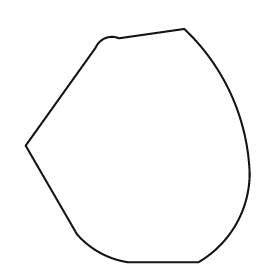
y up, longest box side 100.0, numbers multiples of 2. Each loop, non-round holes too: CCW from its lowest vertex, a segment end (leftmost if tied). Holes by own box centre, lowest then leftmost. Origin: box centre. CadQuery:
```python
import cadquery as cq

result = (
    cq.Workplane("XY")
    .moveTo(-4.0, -50.0)
    .lineTo(26.0, -50.0)
    .threePointArc((42.0, -34.0), (48.0, -12.0))
    .threePointArc((40.0, 22.0), (20.0, 50.0))
    .lineTo(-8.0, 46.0)
    .threePointArc((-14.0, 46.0), (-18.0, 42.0))
    .lineTo(-48.0, 0.0)
    .lineTo(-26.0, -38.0)
    .threePointArc((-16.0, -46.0), (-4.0, -50.0))
    .close()
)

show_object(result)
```